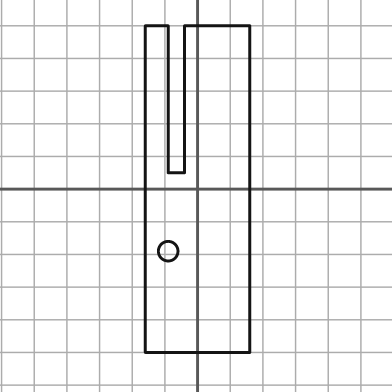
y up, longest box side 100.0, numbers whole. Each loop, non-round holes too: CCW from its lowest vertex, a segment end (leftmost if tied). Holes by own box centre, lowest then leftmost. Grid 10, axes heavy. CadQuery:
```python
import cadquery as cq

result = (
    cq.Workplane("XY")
    .moveTo(-16.0, -50.0)
    .lineTo(16.0, -50.0)
    .lineTo(16.0, 50.0)
    .lineTo(-4.0, 50.0)
    .lineTo(-4.0, 5.0)
    .lineTo(-9.0, 5.0)
    .lineTo(-9.0, 50.0)
    .lineTo(-16.0, 50.0)
    .close()
    .moveTo(-9.0, -19.0)
    .circle(3.0)
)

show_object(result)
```